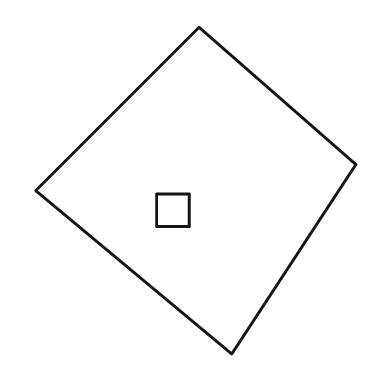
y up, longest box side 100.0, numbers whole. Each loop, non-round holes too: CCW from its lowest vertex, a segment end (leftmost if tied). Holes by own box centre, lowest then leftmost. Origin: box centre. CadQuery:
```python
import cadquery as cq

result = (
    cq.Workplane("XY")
    .moveTo(11.0, -50.0)
    .lineTo(49.0, 8.0)
    .lineTo(1.0, 50.0)
    .lineTo(-49.0, 0.0)
    .close()
    .moveTo(-12.0, -11.0)
    .lineTo(-2.0, -11.0)
    .lineTo(-2.0, -1.0)
    .lineTo(-12.0, -1.0)
    .close()
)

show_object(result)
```